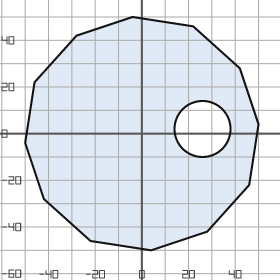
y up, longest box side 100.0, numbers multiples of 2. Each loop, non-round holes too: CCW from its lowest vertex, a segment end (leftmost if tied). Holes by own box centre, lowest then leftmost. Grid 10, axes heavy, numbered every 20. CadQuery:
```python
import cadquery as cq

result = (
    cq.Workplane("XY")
    .moveTo(4.0, -50.0)
    .lineTo(28.0, -42.0)
    .lineTo(46.0, -22.0)
    .lineTo(50.0, 4.0)
    .lineTo(42.0, 28.0)
    .lineTo(22.0, 46.0)
    .lineTo(-4.0, 50.0)
    .lineTo(-28.0, 42.0)
    .lineTo(-46.0, 22.0)
    .lineTo(-50.0, -4.0)
    .lineTo(-42.0, -28.0)
    .lineTo(-22.0, -46.0)
    .close()
    .moveTo(26.0, 2.0)
    .circle(12.0)
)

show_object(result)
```